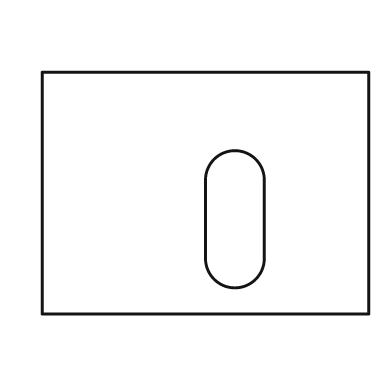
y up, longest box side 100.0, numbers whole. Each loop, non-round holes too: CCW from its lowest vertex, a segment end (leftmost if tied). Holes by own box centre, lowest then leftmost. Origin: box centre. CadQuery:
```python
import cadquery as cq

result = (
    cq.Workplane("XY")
    .moveTo(-50.0, -37.0)
    .lineTo(50.0, -37.0)
    .lineTo(50.0, 37.0)
    .lineTo(-50.0, 37.0)
    .close()
    .moveTo(0.0, -20.0)
    .threePointArc((9.0, -29.0), (18.0, -20.0))
    .lineTo(18.0, 4.0)
    .threePointArc((9.0, 13.0), (0.0, 4.0))
    .close()
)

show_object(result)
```